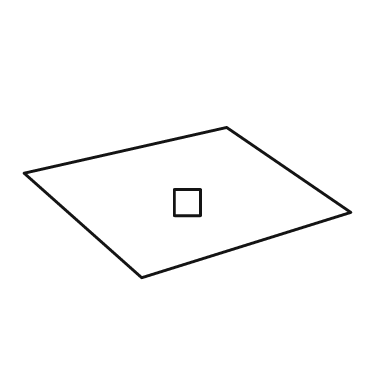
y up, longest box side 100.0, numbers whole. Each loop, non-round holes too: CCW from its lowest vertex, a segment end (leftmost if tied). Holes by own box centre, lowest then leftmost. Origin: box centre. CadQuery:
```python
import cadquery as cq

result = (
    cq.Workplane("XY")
    .moveTo(-14.0, -23.0)
    .lineTo(50.0, -3.0)
    .lineTo(12.0, 23.0)
    .lineTo(-50.0, 9.0)
    .close()
    .moveTo(-4.0, -4.0)
    .lineTo(4.0, -4.0)
    .lineTo(4.0, 4.0)
    .lineTo(-4.0, 4.0)
    .close()
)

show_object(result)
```